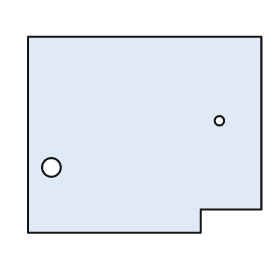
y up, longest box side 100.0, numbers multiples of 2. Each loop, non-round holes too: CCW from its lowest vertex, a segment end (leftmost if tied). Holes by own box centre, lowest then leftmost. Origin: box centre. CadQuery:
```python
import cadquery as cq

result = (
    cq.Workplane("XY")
    .moveTo(-50.0, -42.0)
    .lineTo(24.0, -42.0)
    .lineTo(24.0, -32.0)
    .lineTo(50.0, -32.0)
    .lineTo(50.0, 42.0)
    .lineTo(-50.0, 42.0)
    .close()
    .moveTo(-40.0, -14.0)
    .circle(4.0)
    .moveTo(32.0, 6.0)
    .circle(2.0)
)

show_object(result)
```